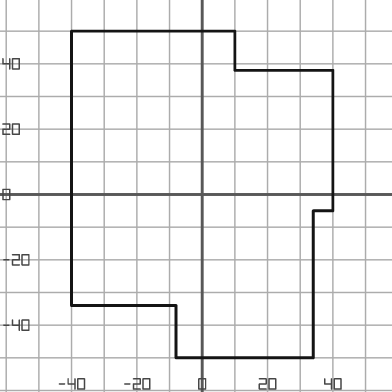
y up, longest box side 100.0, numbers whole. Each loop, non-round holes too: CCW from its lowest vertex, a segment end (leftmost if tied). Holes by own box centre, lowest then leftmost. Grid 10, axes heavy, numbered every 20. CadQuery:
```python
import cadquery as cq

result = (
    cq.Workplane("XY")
    .moveTo(-8.0, -50.0)
    .lineTo(34.0, -50.0)
    .lineTo(34.0, -5.0)
    .lineTo(40.0, -5.0)
    .lineTo(40.0, 38.0)
    .lineTo(10.0, 38.0)
    .lineTo(10.0, 50.0)
    .lineTo(-40.0, 50.0)
    .lineTo(-40.0, -34.0)
    .lineTo(-8.0, -34.0)
    .close()
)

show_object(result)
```